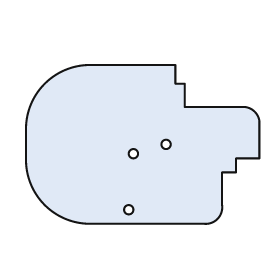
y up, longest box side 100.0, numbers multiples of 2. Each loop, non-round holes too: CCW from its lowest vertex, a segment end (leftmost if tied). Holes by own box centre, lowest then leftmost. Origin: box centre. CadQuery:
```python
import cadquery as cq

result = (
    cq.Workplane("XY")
    .moveTo(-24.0, -34.0)
    .lineTo(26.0, -34.0)
    .threePointArc((32.0, -32.0), (34.0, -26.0))
    .lineTo(34.0, -12.0)
    .lineTo(40.0, -12.0)
    .lineTo(40.0, -6.0)
    .lineTo(50.0, -6.0)
    .lineTo(50.0, 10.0)
    .threePointArc((48.0, 14.0), (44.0, 16.0))
    .lineTo(18.0, 16.0)
    .lineTo(18.0, 26.0)
    .lineTo(14.0, 26.0)
    .lineTo(14.0, 34.0)
    .lineTo(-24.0, 34.0)
    .threePointArc((-42.0, 26.0), (-50.0, 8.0))
    .lineTo(-50.0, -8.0)
    .threePointArc((-42.0, -26.0), (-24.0, -34.0))
    .close()
    .moveTo(-6.0, -28.0)
    .circle(2.0)
    .moveTo(-4.0, -4.0)
    .circle(2.0)
    .moveTo(10.0, 0.0)
    .circle(2.0)
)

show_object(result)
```